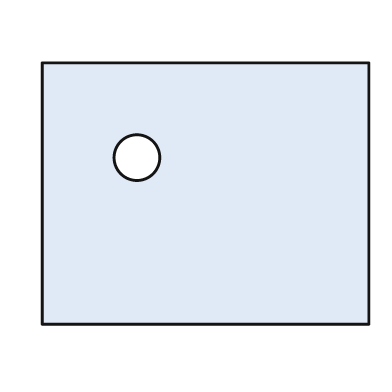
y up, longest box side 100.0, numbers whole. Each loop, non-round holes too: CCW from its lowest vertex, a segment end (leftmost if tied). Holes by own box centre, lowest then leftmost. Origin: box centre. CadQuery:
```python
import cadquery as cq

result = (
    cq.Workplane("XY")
    .moveTo(-50.0, -40.0)
    .lineTo(50.0, -40.0)
    .lineTo(50.0, 40.0)
    .lineTo(-50.0, 40.0)
    .close()
    .moveTo(-21.0, 11.0)
    .circle(7.0)
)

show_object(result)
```